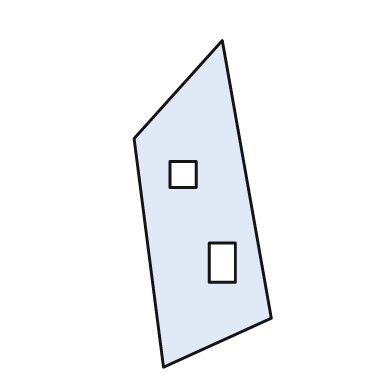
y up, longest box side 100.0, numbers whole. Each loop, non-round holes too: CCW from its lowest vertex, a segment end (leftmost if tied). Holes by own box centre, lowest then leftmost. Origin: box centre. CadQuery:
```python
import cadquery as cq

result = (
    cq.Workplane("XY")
    .moveTo(-12.0, -50.0)
    .lineTo(21.0, -35.0)
    .lineTo(6.0, 50.0)
    .lineTo(-21.0, 20.0)
    .close()
    .moveTo(2.0, -24.0)
    .lineTo(10.0, -24.0)
    .lineTo(10.0, -12.0)
    .lineTo(2.0, -12.0)
    .close()
    .moveTo(-10.0, 5.0)
    .lineTo(-2.0, 5.0)
    .lineTo(-2.0, 13.0)
    .lineTo(-10.0, 13.0)
    .close()
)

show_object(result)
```